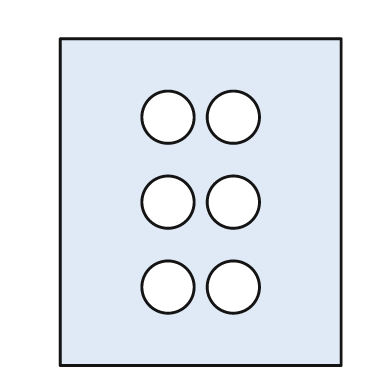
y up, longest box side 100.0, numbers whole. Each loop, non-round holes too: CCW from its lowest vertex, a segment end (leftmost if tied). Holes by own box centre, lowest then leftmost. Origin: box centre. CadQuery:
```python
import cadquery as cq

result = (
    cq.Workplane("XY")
    .moveTo(-43.0, -50.0)
    .lineTo(43.0, -50.0)
    .lineTo(43.0, 50.0)
    .lineTo(-43.0, 50.0)
    .close()
    .moveTo(-10.0, -26.0)
    .circle(8.0)
    .moveTo(10.0, -26.0)
    .circle(8.0)
    .moveTo(-10.0, 0.0)
    .circle(8.0)
    .moveTo(10.0, 0.0)
    .circle(8.0)
    .moveTo(-10.0, 26.0)
    .circle(8.0)
    .moveTo(10.0, 26.0)
    .circle(8.0)
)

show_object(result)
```